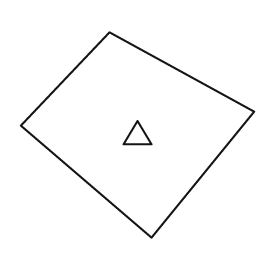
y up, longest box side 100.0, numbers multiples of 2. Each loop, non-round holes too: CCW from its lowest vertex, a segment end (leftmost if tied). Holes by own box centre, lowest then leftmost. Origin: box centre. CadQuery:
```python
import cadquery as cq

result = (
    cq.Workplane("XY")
    .moveTo(6.0, -44.0)
    .lineTo(50.0, 10.0)
    .lineTo(-12.0, 44.0)
    .lineTo(-50.0, 4.0)
    .close()
    .moveTo(-6.0, -4.0)
    .lineTo(6.0, -4.0)
    .lineTo(0.0, 6.0)
    .close()
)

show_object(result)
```